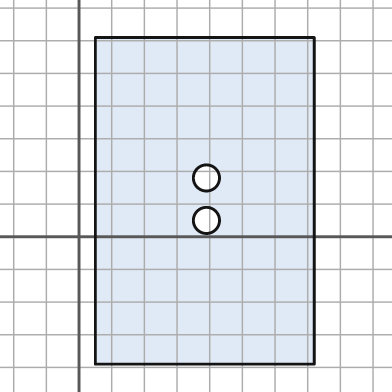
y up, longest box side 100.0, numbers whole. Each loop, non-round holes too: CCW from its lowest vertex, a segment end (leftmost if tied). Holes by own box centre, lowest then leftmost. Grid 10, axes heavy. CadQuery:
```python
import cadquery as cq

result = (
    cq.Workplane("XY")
    .moveTo(5.0, -39.0)
    .lineTo(72.0, -39.0)
    .lineTo(72.0, 61.0)
    .lineTo(5.0, 61.0)
    .close()
    .moveTo(39.0, 5.0)
    .circle(4.0)
    .moveTo(39.0, 18.0)
    .circle(4.0)
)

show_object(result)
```